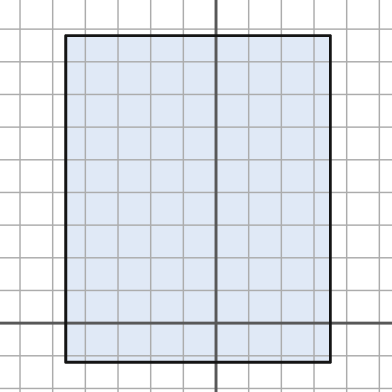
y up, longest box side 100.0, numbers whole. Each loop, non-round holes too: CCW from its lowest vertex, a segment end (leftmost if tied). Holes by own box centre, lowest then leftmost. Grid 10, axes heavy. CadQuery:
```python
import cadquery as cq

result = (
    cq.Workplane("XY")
    .moveTo(-46.0, -12.0)
    .lineTo(35.0, -12.0)
    .lineTo(35.0, 88.0)
    .lineTo(-46.0, 88.0)
    .close()
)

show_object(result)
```